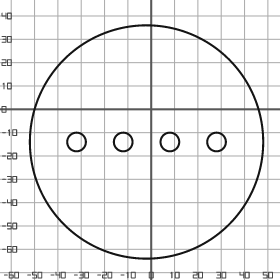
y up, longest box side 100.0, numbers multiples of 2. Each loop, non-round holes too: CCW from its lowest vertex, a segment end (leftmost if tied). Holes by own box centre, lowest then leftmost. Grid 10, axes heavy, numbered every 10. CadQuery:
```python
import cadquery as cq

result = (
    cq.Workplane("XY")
    .moveTo(-2.0, -14.0)
    .circle(50.0)
    .moveTo(-32.0, -14.0)
    .circle(4.0)
    .moveTo(-12.0, -14.0)
    .circle(4.0)
    .moveTo(8.0, -14.0)
    .circle(4.0)
    .moveTo(28.0, -14.0)
    .circle(4.0)
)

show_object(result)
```